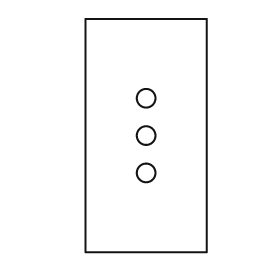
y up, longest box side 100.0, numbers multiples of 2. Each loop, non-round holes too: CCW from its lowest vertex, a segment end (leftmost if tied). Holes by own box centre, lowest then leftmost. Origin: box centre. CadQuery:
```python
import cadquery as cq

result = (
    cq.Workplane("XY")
    .moveTo(-26.0, -50.0)
    .lineTo(26.0, -50.0)
    .lineTo(26.0, 50.0)
    .lineTo(-26.0, 50.0)
    .close()
    .moveTo(0.0, -16.0)
    .circle(4.0)
    .moveTo(0.0, 0.0)
    .circle(4.0)
    .moveTo(0.0, 16.0)
    .circle(4.0)
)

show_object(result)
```